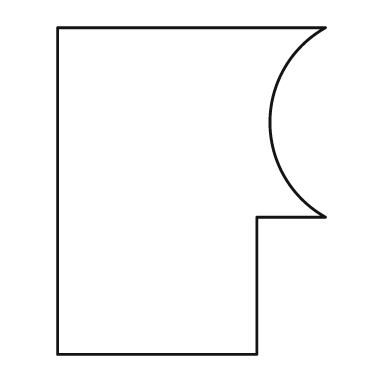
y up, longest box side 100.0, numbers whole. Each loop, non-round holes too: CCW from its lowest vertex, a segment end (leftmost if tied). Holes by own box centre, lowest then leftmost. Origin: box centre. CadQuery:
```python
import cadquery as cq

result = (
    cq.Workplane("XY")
    .moveTo(-41.0, -50.0)
    .lineTo(20.0, -50.0)
    .lineTo(20.0, -8.0)
    .lineTo(41.0, -8.0)
    .threePointArc((24.0, 21.0), (41.0, 50.0))
    .lineTo(-41.0, 50.0)
    .close()
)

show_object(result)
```